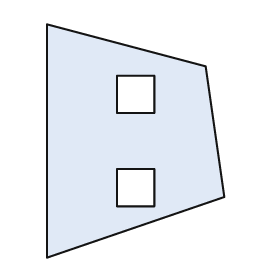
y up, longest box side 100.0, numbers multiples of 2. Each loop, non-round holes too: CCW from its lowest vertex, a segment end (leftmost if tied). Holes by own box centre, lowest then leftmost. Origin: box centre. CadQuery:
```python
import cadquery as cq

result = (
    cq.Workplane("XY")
    .moveTo(-38.0, -50.0)
    .lineTo(38.0, -24.0)
    .lineTo(30.0, 32.0)
    .lineTo(-38.0, 50.0)
    .close()
    .moveTo(-8.0, -28.0)
    .lineTo(8.0, -28.0)
    .lineTo(8.0, -12.0)
    .lineTo(-8.0, -12.0)
    .close()
    .moveTo(-8.0, 12.0)
    .lineTo(8.0, 12.0)
    .lineTo(8.0, 28.0)
    .lineTo(-8.0, 28.0)
    .close()
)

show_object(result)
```